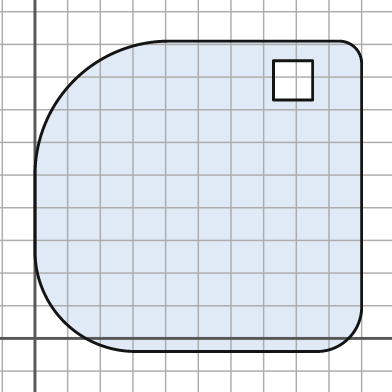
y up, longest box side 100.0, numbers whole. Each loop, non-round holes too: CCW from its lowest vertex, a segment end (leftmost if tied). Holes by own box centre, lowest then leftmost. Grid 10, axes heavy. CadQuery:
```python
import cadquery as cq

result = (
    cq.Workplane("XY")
    .moveTo(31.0, -4.0)
    .lineTo(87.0, -4.0)
    .threePointArc((96.0, 0.0), (100.0, 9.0))
    .lineTo(100.0, 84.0)
    .threePointArc((98.0, 89.0), (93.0, 91.0))
    .lineTo(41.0, 91.0)
    .threePointArc((12.0, 79.0), (0.0, 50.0))
    .lineTo(0.0, 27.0)
    .threePointArc((9.0, 5.0), (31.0, -4.0))
    .close()
    .moveTo(73.0, 73.0)
    .lineTo(85.0, 73.0)
    .lineTo(85.0, 85.0)
    .lineTo(73.0, 85.0)
    .close()
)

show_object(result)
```